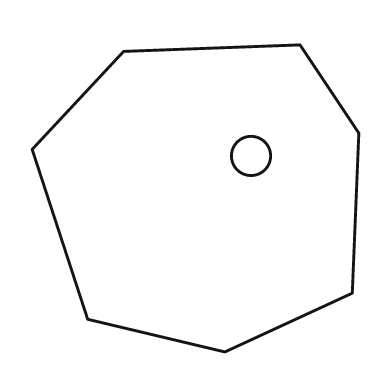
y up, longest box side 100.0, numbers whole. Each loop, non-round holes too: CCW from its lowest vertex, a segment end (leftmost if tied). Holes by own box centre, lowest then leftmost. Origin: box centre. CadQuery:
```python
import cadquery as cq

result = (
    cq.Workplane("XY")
    .moveTo(9.0, -47.0)
    .lineTo(48.0, -29.0)
    .lineTo(50.0, 20.0)
    .lineTo(32.0, 47.0)
    .lineTo(-22.0, 45.0)
    .lineTo(-50.0, 15.0)
    .lineTo(-33.0, -37.0)
    .close()
    .moveTo(17.0, 13.0)
    .circle(6.0)
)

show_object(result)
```